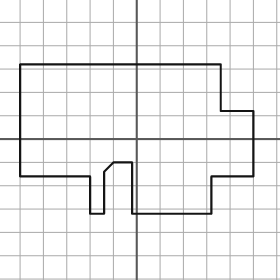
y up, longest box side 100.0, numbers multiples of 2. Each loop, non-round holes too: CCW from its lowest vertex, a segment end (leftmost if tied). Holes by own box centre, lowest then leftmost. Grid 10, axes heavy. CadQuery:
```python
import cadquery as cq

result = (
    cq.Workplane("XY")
    .moveTo(-20.0, -32.0)
    .lineTo(-14.0, -32.0)
    .lineTo(-14.0, -14.0)
    .lineTo(-10.0, -10.0)
    .lineTo(-2.0, -10.0)
    .lineTo(-2.0, -32.0)
    .lineTo(32.0, -32.0)
    .lineTo(32.0, -16.0)
    .lineTo(50.0, -16.0)
    .lineTo(50.0, 12.0)
    .lineTo(36.0, 12.0)
    .lineTo(36.0, 32.0)
    .lineTo(-50.0, 32.0)
    .lineTo(-50.0, -16.0)
    .lineTo(-20.0, -16.0)
    .close()
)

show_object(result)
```